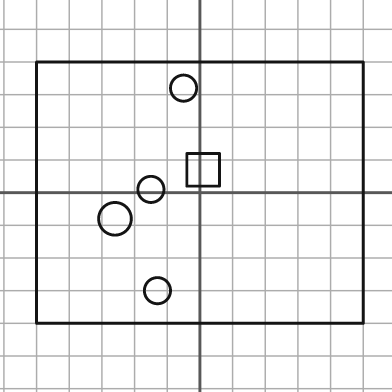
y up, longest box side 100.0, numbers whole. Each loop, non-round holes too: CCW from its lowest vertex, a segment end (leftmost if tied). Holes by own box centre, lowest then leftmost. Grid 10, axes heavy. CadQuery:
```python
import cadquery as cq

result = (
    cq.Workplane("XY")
    .moveTo(-50.0, -40.0)
    .lineTo(50.0, -40.0)
    .lineTo(50.0, 40.0)
    .lineTo(-50.0, 40.0)
    .close()
    .moveTo(-13.0, -30.0)
    .circle(4.0)
    .moveTo(-26.0, -8.0)
    .circle(5.0)
    .moveTo(-15.0, 1.0)
    .circle(4.0)
    .moveTo(-4.0, 2.0)
    .lineTo(6.0, 2.0)
    .lineTo(6.0, 12.0)
    .lineTo(-4.0, 12.0)
    .close()
    .moveTo(-5.0, 32.0)
    .circle(4.0)
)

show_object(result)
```